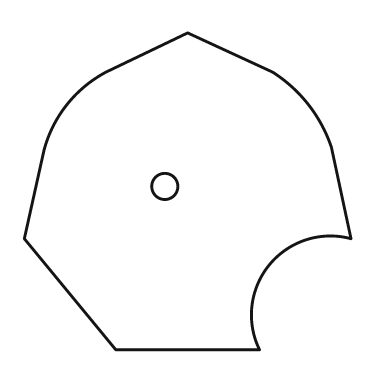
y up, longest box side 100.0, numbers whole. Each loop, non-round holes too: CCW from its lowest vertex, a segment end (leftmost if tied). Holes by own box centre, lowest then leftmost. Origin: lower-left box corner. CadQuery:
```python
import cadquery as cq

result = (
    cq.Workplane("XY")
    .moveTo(28.0, 0.0)
    .lineTo(72.0, 0.0)
    .threePointArc((75.0, 26.0), (100.0, 34.0))
    .lineTo(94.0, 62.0)
    .threePointArc((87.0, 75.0), (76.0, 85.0))
    .lineTo(50.0, 97.0)
    .lineTo(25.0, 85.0)
    .threePointArc((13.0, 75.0), (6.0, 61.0))
    .lineTo(0.0, 34.0)
    .close()
    .moveTo(43.0, 50.0)
    .circle(4.0)
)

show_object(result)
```